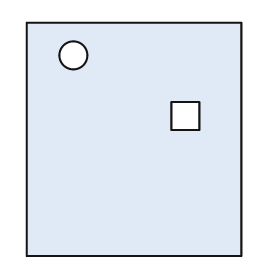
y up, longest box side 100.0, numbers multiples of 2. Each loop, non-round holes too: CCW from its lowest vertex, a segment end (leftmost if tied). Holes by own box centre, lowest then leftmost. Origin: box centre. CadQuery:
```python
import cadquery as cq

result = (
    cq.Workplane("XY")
    .moveTo(-46.0, -50.0)
    .lineTo(46.0, -50.0)
    .lineTo(46.0, 50.0)
    .lineTo(-46.0, 50.0)
    .close()
    .moveTo(16.0, 4.0)
    .lineTo(28.0, 4.0)
    .lineTo(28.0, 16.0)
    .lineTo(16.0, 16.0)
    .close()
    .moveTo(-26.0, 36.0)
    .circle(6.0)
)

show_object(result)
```